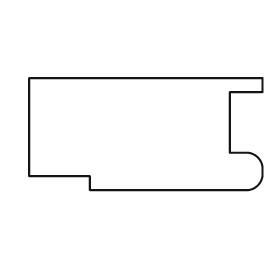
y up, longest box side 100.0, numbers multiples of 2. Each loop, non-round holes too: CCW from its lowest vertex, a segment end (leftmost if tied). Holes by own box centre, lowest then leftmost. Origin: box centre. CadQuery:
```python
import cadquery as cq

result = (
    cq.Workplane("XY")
    .moveTo(-24.0, -24.0)
    .lineTo(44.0, -24.0)
    .threePointArc((48.0, -22.0), (50.0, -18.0))
    .lineTo(50.0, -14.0)
    .threePointArc((48.0, -10.0), (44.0, -8.0))
    .lineTo(36.0, -8.0)
    .lineTo(36.0, 18.0)
    .lineTo(50.0, 18.0)
    .lineTo(50.0, 24.0)
    .lineTo(-50.0, 24.0)
    .lineTo(-50.0, -18.0)
    .lineTo(-24.0, -18.0)
    .close()
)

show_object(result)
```